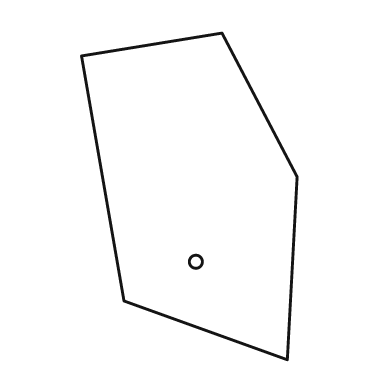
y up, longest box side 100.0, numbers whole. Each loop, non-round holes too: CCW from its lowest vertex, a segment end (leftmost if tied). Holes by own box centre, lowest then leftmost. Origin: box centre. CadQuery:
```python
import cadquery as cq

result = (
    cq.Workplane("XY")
    .moveTo(30.0, -50.0)
    .lineTo(33.0, 6.0)
    .lineTo(10.0, 50.0)
    .lineTo(-33.0, 43.0)
    .lineTo(-20.0, -32.0)
    .close()
    .moveTo(2.0, -20.0)
    .circle(2.0)
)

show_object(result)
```